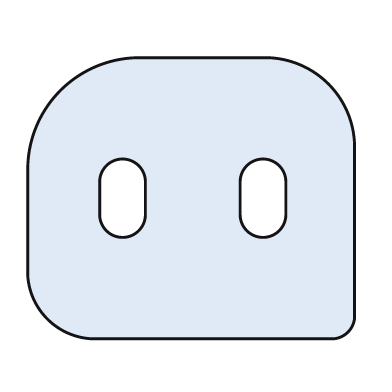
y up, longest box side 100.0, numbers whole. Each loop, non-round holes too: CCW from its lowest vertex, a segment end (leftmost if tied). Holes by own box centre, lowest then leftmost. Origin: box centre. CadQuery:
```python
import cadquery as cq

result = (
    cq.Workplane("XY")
    .moveTo(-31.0, -43.0)
    .lineTo(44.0, -43.0)
    .threePointArc((48.0, -41.0), (50.0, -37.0))
    .lineTo(50.0, 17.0)
    .threePointArc((42.0, 35.0), (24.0, 43.0))
    .lineTo(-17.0, 43.0)
    .threePointArc((-40.0, 33.0), (-50.0, 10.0))
    .lineTo(-50.0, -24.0)
    .threePointArc((-44.0, -37.0), (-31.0, -43.0))
    .close()
    .moveTo(-28.0, -5.0)
    .threePointArc((-21.0, -12.0), (-14.0, -5.0))
    .lineTo(-14.0, 5.0)
    .threePointArc((-21.0, 12.0), (-28.0, 5.0))
    .close()
    .moveTo(15.0, -5.0)
    .threePointArc((22.0, -12.0), (29.0, -5.0))
    .lineTo(29.0, 5.0)
    .threePointArc((22.0, 12.0), (15.0, 5.0))
    .close()
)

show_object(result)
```